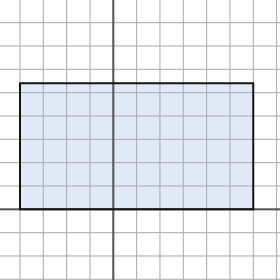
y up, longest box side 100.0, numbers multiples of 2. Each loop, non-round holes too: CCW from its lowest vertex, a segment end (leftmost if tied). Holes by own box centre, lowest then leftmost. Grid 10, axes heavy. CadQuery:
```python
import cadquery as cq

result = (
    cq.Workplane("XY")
    .moveTo(-40.0, 0.0)
    .lineTo(60.0, 0.0)
    .lineTo(60.0, 54.0)
    .lineTo(-40.0, 54.0)
    .close()
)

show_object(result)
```